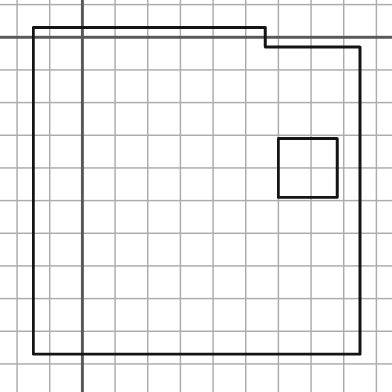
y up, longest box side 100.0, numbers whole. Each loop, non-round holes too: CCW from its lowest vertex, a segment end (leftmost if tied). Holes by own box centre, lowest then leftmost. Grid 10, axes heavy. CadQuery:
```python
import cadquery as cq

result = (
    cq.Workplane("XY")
    .moveTo(-15.0, -97.0)
    .lineTo(85.0, -97.0)
    .lineTo(85.0, -3.0)
    .lineTo(56.0, -3.0)
    .lineTo(56.0, 3.0)
    .lineTo(-15.0, 3.0)
    .close()
    .moveTo(60.0, -49.0)
    .lineTo(78.0, -49.0)
    .lineTo(78.0, -31.0)
    .lineTo(60.0, -31.0)
    .close()
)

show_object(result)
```